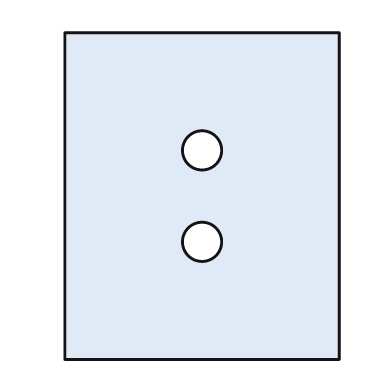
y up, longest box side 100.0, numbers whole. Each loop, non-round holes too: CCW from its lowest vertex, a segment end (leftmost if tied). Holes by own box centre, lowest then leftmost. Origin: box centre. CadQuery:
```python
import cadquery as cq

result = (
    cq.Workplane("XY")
    .moveTo(-42.0, -50.0)
    .lineTo(42.0, -50.0)
    .lineTo(42.0, 50.0)
    .lineTo(-42.0, 50.0)
    .close()
    .moveTo(0.0, -14.0)
    .circle(6.0)
    .moveTo(0.0, 14.0)
    .circle(6.0)
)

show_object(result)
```